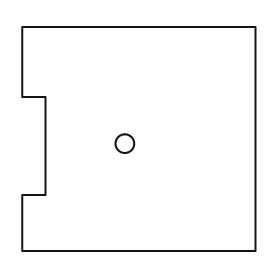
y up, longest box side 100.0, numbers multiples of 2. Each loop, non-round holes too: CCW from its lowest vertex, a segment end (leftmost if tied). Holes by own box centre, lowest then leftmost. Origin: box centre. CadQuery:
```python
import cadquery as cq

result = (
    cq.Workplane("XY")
    .moveTo(-50.0, -48.0)
    .lineTo(50.0, -48.0)
    .lineTo(50.0, 48.0)
    .lineTo(-50.0, 48.0)
    .lineTo(-50.0, 18.0)
    .lineTo(-40.0, 18.0)
    .lineTo(-40.0, -24.0)
    .lineTo(-50.0, -24.0)
    .close()
    .moveTo(-6.0, -2.0)
    .circle(4.0)
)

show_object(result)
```